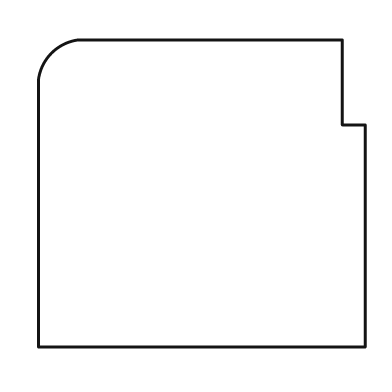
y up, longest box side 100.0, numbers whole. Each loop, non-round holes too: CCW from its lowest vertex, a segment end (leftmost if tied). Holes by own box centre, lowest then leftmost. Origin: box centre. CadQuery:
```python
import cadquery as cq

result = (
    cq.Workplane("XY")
    .moveTo(-50.0, -47.0)
    .lineTo(50.0, -47.0)
    .lineTo(50.0, 21.0)
    .lineTo(43.0, 21.0)
    .lineTo(43.0, 47.0)
    .lineTo(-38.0, 47.0)
    .threePointArc((-46.0, 43.0), (-50.0, 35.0))
    .close()
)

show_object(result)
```